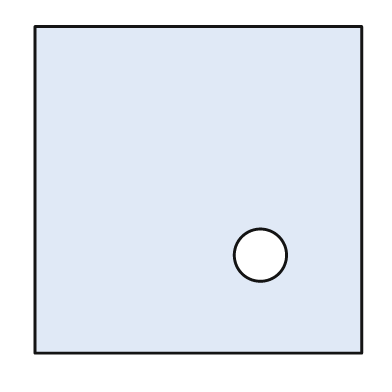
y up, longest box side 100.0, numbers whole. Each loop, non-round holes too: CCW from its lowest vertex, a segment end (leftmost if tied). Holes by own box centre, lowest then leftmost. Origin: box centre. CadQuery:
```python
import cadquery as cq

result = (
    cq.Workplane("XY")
    .moveTo(-50.0, -50.0)
    .lineTo(50.0, -50.0)
    .lineTo(50.0, 50.0)
    .lineTo(-50.0, 50.0)
    .close()
    .moveTo(19.0, -20.0)
    .circle(8.0)
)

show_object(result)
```